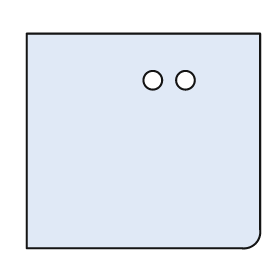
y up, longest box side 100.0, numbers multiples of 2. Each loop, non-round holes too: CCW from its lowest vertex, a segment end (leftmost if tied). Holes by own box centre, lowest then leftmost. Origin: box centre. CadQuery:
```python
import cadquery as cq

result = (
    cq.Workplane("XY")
    .moveTo(-50.0, -46.0)
    .lineTo(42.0, -46.0)
    .threePointArc((48.0, -44.0), (50.0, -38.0))
    .lineTo(50.0, 46.0)
    .lineTo(-50.0, 46.0)
    .close()
    .moveTo(4.0, 26.0)
    .circle(4.0)
    .moveTo(18.0, 26.0)
    .circle(4.0)
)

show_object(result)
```